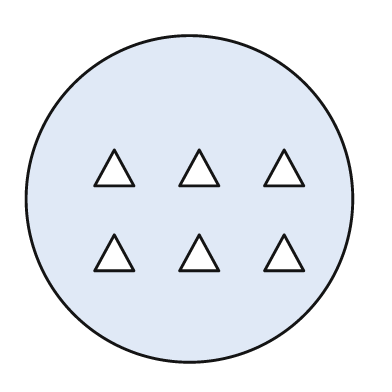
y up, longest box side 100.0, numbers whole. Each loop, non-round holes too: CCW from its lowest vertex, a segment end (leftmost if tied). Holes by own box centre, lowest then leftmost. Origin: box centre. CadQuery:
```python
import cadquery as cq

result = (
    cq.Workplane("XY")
    .moveTo(0.0, 0.0)
    .circle(50.0)
    .moveTo(-29.0, -22.0)
    .lineTo(-17.0, -22.0)
    .lineTo(-23.0, -11.0)
    .close()
    .moveTo(-3.0, -22.0)
    .lineTo(9.0, -22.0)
    .lineTo(3.0, -11.0)
    .close()
    .moveTo(23.0, -22.0)
    .lineTo(35.0, -22.0)
    .lineTo(29.0, -11.0)
    .close()
    .moveTo(-29.0, 4.0)
    .lineTo(-17.0, 4.0)
    .lineTo(-23.0, 15.0)
    .close()
    .moveTo(-3.0, 4.0)
    .lineTo(9.0, 4.0)
    .lineTo(3.0, 15.0)
    .close()
    .moveTo(23.0, 4.0)
    .lineTo(35.0, 4.0)
    .lineTo(29.0, 15.0)
    .close()
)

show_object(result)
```